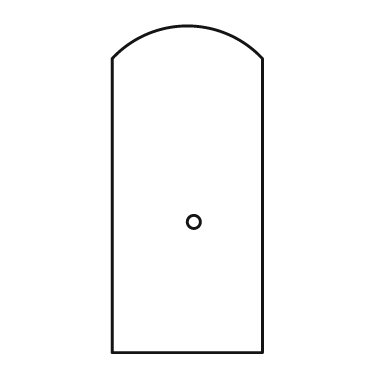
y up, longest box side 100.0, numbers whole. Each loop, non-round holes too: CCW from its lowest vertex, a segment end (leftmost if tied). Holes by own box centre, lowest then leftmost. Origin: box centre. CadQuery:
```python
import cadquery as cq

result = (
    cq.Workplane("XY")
    .moveTo(-23.0, -50.0)
    .lineTo(23.0, -50.0)
    .lineTo(23.0, 40.0)
    .threePointArc((0.0, 50.0), (-23.0, 40.0))
    .close()
    .moveTo(2.0, -10.0)
    .circle(2.0)
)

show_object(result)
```